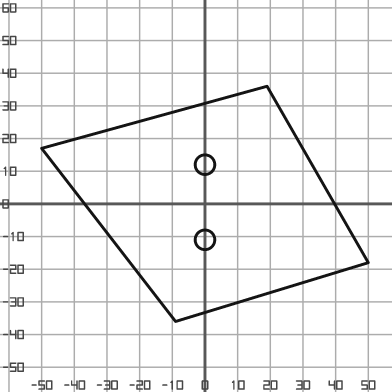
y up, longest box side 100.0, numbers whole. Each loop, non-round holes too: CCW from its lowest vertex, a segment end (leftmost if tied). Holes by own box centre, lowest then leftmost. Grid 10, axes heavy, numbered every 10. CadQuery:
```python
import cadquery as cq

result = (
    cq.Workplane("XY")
    .moveTo(-9.0, -36.0)
    .lineTo(50.0, -18.0)
    .lineTo(19.0, 36.0)
    .lineTo(-50.0, 17.0)
    .close()
    .moveTo(0.0, -11.0)
    .circle(3.0)
    .moveTo(0.0, 12.0)
    .circle(3.0)
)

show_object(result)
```